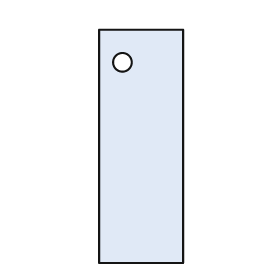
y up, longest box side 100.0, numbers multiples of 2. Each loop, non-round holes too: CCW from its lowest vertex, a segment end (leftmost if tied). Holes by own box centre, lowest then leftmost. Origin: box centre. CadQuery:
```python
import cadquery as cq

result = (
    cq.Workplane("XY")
    .moveTo(-18.0, -50.0)
    .lineTo(18.0, -50.0)
    .lineTo(18.0, 50.0)
    .lineTo(-18.0, 50.0)
    .close()
    .moveTo(-8.0, 36.0)
    .circle(4.0)
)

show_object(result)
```